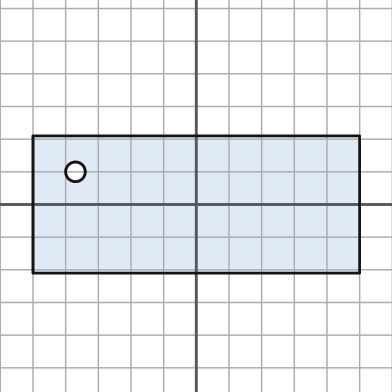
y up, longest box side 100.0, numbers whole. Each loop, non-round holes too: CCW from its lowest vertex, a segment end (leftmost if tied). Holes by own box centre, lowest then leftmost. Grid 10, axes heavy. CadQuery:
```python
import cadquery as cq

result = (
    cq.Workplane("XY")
    .moveTo(-50.0, -21.0)
    .lineTo(50.0, -21.0)
    .lineTo(50.0, 21.0)
    .lineTo(-50.0, 21.0)
    .close()
    .moveTo(-37.0, 10.0)
    .circle(3.0)
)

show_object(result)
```